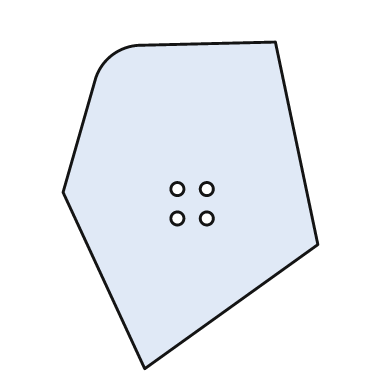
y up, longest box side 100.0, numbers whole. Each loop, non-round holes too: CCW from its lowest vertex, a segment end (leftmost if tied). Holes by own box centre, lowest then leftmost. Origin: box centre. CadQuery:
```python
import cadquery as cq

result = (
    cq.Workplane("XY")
    .moveTo(-14.0, -50.0)
    .lineTo(39.0, -12.0)
    .lineTo(26.0, 50.0)
    .lineTo(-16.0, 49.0)
    .threePointArc((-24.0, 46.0), (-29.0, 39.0))
    .lineTo(-39.0, 4.0)
    .close()
    .moveTo(-4.0, -4.0)
    .circle(2.0)
    .moveTo(5.0, -4.0)
    .circle(2.0)
    .moveTo(-4.0, 5.0)
    .circle(2.0)
    .moveTo(5.0, 5.0)
    .circle(2.0)
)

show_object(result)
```